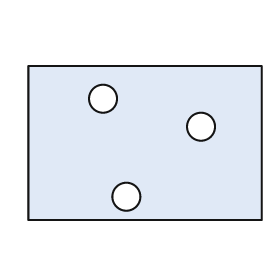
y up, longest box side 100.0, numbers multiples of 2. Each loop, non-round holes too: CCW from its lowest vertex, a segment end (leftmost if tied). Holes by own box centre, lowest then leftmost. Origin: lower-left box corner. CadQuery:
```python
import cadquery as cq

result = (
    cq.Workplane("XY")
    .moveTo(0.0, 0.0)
    .lineTo(100.0, 0.0)
    .lineTo(100.0, 66.0)
    .lineTo(0.0, 66.0)
    .close()
    .moveTo(42.0, 10.0)
    .circle(6.0)
    .moveTo(74.0, 40.0)
    .circle(6.0)
    .moveTo(32.0, 52.0)
    .circle(6.0)
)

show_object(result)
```